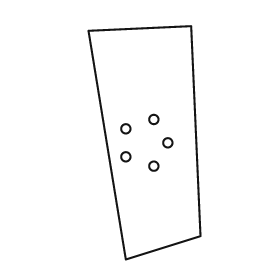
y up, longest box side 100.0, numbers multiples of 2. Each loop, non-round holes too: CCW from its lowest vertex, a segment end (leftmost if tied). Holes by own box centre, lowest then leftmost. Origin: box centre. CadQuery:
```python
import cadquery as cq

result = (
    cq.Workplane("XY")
    .moveTo(-8.0, -50.0)
    .lineTo(24.0, -40.0)
    .lineTo(20.0, 50.0)
    .lineTo(-24.0, 48.0)
    .close()
    .moveTo(4.0, -10.0)
    .circle(2.0)
    .moveTo(-8.0, -6.0)
    .circle(2.0)
    .moveTo(10.0, 0.0)
    .circle(2.0)
    .moveTo(-8.0, 6.0)
    .circle(2.0)
    .moveTo(4.0, 10.0)
    .circle(2.0)
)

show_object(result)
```